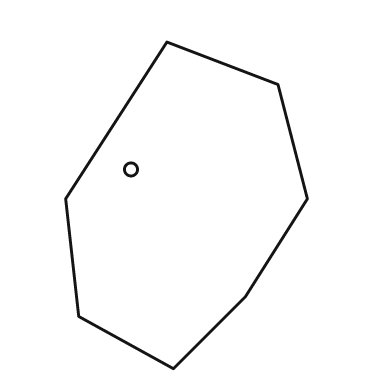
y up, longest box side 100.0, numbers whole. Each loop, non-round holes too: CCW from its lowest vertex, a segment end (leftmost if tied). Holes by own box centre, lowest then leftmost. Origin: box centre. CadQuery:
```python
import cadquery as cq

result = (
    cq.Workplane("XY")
    .moveTo(-4.0, -50.0)
    .lineTo(18.0, -28.0)
    .lineTo(37.0, 2.0)
    .lineTo(28.0, 37.0)
    .lineTo(-6.0, 50.0)
    .lineTo(-37.0, 2.0)
    .lineTo(-33.0, -34.0)
    .close()
    .moveTo(-17.0, 11.0)
    .circle(2.0)
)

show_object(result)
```